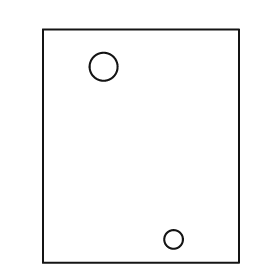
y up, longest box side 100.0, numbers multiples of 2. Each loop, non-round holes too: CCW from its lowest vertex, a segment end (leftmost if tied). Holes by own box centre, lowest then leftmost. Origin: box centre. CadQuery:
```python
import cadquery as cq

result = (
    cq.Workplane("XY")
    .moveTo(-42.0, -50.0)
    .lineTo(42.0, -50.0)
    .lineTo(42.0, 50.0)
    .lineTo(-42.0, 50.0)
    .close()
    .moveTo(14.0, -40.0)
    .circle(4.0)
    .moveTo(-16.0, 34.0)
    .circle(6.0)
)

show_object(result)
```